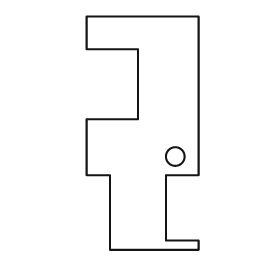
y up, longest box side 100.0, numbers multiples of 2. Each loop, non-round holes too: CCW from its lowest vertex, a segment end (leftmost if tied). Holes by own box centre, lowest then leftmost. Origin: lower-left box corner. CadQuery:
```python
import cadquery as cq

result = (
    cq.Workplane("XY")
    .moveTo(10.0, 0.0)
    .lineTo(48.0, 0.0)
    .lineTo(48.0, 4.0)
    .lineTo(34.0, 4.0)
    .lineTo(34.0, 32.0)
    .lineTo(48.0, 32.0)
    .lineTo(48.0, 100.0)
    .lineTo(0.0, 100.0)
    .lineTo(0.0, 86.0)
    .lineTo(22.0, 86.0)
    .lineTo(22.0, 56.0)
    .lineTo(0.0, 56.0)
    .lineTo(0.0, 32.0)
    .lineTo(10.0, 32.0)
    .close()
    .moveTo(38.0, 40.0)
    .circle(4.0)
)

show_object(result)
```